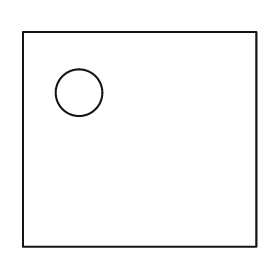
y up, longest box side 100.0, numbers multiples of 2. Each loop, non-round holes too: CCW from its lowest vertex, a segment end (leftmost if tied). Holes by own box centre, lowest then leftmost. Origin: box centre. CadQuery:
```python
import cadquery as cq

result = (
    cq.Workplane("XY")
    .moveTo(-50.0, -46.0)
    .lineTo(50.0, -46.0)
    .lineTo(50.0, 46.0)
    .lineTo(-50.0, 46.0)
    .close()
    .moveTo(-26.0, 20.0)
    .circle(10.0)
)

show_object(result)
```